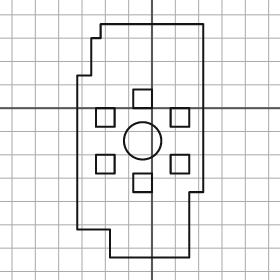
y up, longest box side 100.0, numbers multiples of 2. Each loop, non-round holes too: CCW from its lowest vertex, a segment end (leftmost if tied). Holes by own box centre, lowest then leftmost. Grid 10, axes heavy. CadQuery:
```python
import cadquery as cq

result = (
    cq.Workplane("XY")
    .moveTo(-18.0, -64.0)
    .lineTo(16.0, -64.0)
    .lineTo(16.0, -36.0)
    .lineTo(22.0, -36.0)
    .lineTo(22.0, 36.0)
    .lineTo(-22.0, 36.0)
    .lineTo(-22.0, 30.0)
    .lineTo(-26.0, 30.0)
    .lineTo(-26.0, 14.0)
    .lineTo(-32.0, 14.0)
    .lineTo(-32.0, -52.0)
    .lineTo(-18.0, -52.0)
    .close()
    .moveTo(-8.0, -36.0)
    .lineTo(0.0, -36.0)
    .lineTo(0.0, -28.0)
    .lineTo(-8.0, -28.0)
    .close()
    .moveTo(-24.0, -28.0)
    .lineTo(-16.0, -28.0)
    .lineTo(-16.0, -20.0)
    .lineTo(-24.0, -20.0)
    .close()
    .moveTo(8.0, -28.0)
    .lineTo(16.0, -28.0)
    .lineTo(16.0, -20.0)
    .lineTo(8.0, -20.0)
    .close()
    .moveTo(-4.0, -14.0)
    .circle(8.0)
    .moveTo(-24.0, -8.0)
    .lineTo(-16.0, -8.0)
    .lineTo(-16.0, 0.0)
    .lineTo(-24.0, 0.0)
    .close()
    .moveTo(8.0, -8.0)
    .lineTo(16.0, -8.0)
    .lineTo(16.0, 0.0)
    .lineTo(8.0, 0.0)
    .close()
    .moveTo(-8.0, 0.0)
    .lineTo(0.0, 0.0)
    .lineTo(0.0, 8.0)
    .lineTo(-8.0, 8.0)
    .close()
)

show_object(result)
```